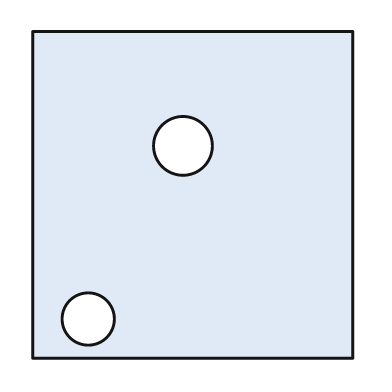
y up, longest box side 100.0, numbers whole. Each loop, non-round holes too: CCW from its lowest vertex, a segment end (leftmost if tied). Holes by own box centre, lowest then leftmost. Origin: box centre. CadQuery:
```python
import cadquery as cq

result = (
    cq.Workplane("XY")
    .moveTo(-49.0, -50.0)
    .lineTo(49.0, -50.0)
    .lineTo(49.0, 50.0)
    .lineTo(-49.0, 50.0)
    .close()
    .moveTo(-32.0, -38.0)
    .circle(8.0)
    .moveTo(-3.0, 15.0)
    .circle(9.0)
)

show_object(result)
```